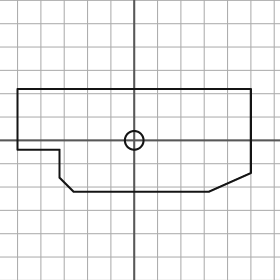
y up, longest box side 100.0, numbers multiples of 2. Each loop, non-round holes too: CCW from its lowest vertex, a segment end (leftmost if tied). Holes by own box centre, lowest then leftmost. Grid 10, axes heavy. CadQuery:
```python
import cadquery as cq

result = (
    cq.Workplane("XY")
    .moveTo(-26.0, -22.0)
    .lineTo(32.0, -22.0)
    .lineTo(50.0, -14.0)
    .lineTo(50.0, 22.0)
    .lineTo(-50.0, 22.0)
    .lineTo(-50.0, -4.0)
    .lineTo(-32.0, -4.0)
    .lineTo(-32.0, -16.0)
    .close()
    .moveTo(0.0, 0.0)
    .circle(4.0)
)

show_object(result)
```